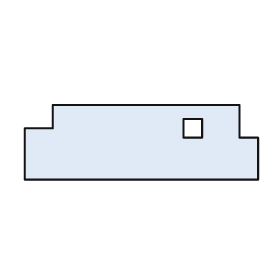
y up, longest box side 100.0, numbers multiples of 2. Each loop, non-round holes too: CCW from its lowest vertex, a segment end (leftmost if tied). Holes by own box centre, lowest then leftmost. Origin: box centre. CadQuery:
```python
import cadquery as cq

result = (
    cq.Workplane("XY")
    .moveTo(-50.0, -16.0)
    .lineTo(50.0, -16.0)
    .lineTo(50.0, 2.0)
    .lineTo(42.0, 2.0)
    .lineTo(42.0, 16.0)
    .lineTo(-38.0, 16.0)
    .lineTo(-38.0, 6.0)
    .lineTo(-50.0, 6.0)
    .close()
    .moveTo(18.0, 2.0)
    .lineTo(26.0, 2.0)
    .lineTo(26.0, 10.0)
    .lineTo(18.0, 10.0)
    .close()
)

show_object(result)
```